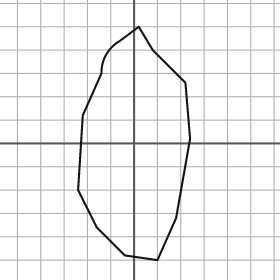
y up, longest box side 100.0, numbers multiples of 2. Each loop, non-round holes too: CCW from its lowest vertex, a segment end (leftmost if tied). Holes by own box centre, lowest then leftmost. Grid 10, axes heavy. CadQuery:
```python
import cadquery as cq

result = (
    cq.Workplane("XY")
    .moveTo(10.0, -50.0)
    .lineTo(18.0, -32.0)
    .lineTo(24.0, 2.0)
    .lineTo(22.0, 26.0)
    .lineTo(8.0, 40.0)
    .lineTo(2.0, 50.0)
    .lineTo(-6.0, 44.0)
    .threePointArc((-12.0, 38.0), (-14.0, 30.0))
    .lineTo(-22.0, 12.0)
    .lineTo(-24.0, -20.0)
    .lineTo(-16.0, -36.0)
    .lineTo(-4.0, -48.0)
    .close()
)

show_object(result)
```